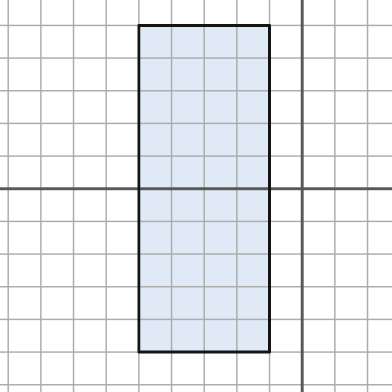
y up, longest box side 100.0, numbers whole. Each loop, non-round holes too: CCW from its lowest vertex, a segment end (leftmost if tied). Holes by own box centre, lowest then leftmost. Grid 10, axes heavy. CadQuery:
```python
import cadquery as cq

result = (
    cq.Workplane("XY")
    .moveTo(-50.0, -50.0)
    .lineTo(-10.0, -50.0)
    .lineTo(-10.0, 50.0)
    .lineTo(-50.0, 50.0)
    .close()
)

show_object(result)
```